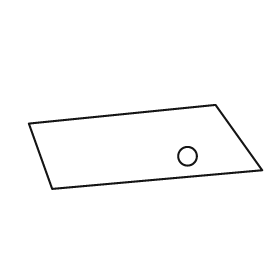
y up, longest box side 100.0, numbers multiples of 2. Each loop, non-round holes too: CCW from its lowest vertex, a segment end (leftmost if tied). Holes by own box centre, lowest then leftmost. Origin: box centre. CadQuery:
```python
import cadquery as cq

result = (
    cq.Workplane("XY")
    .moveTo(-40.0, -18.0)
    .lineTo(50.0, -10.0)
    .lineTo(30.0, 18.0)
    .lineTo(-50.0, 10.0)
    .close()
    .moveTo(18.0, -4.0)
    .circle(4.0)
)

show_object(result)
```